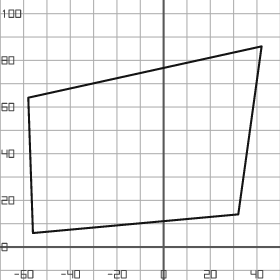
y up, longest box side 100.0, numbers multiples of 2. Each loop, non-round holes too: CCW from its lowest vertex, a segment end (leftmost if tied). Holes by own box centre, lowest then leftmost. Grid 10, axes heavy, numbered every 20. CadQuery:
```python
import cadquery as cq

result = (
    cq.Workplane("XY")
    .moveTo(-56.0, 6.0)
    .lineTo(32.0, 14.0)
    .lineTo(42.0, 86.0)
    .lineTo(-58.0, 64.0)
    .close()
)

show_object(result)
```